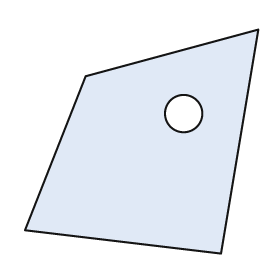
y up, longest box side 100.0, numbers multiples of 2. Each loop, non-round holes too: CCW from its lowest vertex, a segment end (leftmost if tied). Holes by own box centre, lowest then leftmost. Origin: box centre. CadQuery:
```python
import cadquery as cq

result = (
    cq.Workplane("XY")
    .moveTo(34.0, -48.0)
    .lineTo(50.0, 48.0)
    .lineTo(-24.0, 28.0)
    .lineTo(-50.0, -38.0)
    .close()
    .moveTo(18.0, 12.0)
    .circle(8.0)
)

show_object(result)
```